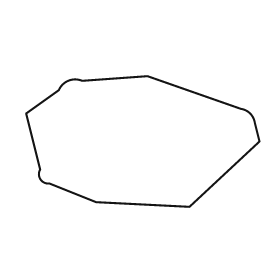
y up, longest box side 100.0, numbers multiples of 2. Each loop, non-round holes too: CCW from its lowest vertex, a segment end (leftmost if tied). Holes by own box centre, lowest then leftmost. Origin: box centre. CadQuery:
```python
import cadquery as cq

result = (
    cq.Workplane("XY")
    .moveTo(20.0, -28.0)
    .lineTo(50.0, 0.0)
    .lineTo(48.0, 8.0)
    .threePointArc((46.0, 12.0), (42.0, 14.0))
    .lineTo(2.0, 28.0)
    .lineTo(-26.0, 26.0)
    .threePointArc((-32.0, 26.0), (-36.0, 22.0))
    .lineTo(-50.0, 12.0)
    .lineTo(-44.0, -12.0)
    .threePointArc((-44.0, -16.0), (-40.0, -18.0))
    .lineTo(-20.0, -26.0)
    .close()
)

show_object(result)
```